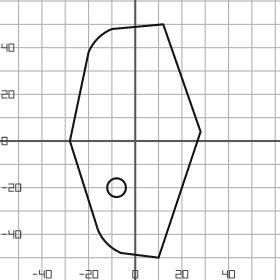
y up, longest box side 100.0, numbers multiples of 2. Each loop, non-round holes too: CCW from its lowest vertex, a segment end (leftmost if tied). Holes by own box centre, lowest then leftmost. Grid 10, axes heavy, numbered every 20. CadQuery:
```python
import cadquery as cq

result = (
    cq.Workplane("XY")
    .moveTo(10.0, -50.0)
    .lineTo(28.0, 4.0)
    .lineTo(12.0, 50.0)
    .lineTo(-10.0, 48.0)
    .threePointArc((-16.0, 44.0), (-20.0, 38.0))
    .lineTo(-28.0, 0.0)
    .lineTo(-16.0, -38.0)
    .threePointArc((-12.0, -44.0), (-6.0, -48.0))
    .close()
    .moveTo(-8.0, -20.0)
    .circle(4.0)
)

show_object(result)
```